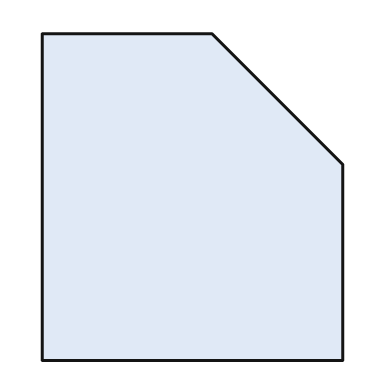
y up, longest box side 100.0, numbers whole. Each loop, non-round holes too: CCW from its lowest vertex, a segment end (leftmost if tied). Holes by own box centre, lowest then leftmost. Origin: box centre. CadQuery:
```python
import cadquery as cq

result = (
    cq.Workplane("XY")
    .moveTo(-46.0, -50.0)
    .lineTo(46.0, -50.0)
    .lineTo(46.0, 10.0)
    .lineTo(6.0, 50.0)
    .lineTo(-46.0, 50.0)
    .close()
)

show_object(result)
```